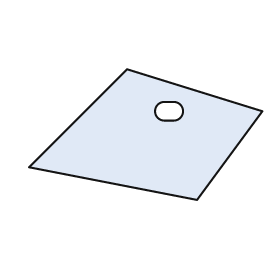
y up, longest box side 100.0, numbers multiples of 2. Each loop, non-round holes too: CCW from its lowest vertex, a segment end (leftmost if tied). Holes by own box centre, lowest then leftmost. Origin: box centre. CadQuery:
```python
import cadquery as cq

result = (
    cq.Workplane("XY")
    .moveTo(22.0, -28.0)
    .lineTo(50.0, 10.0)
    .lineTo(-8.0, 28.0)
    .lineTo(-50.0, -14.0)
    .close()
    .moveTo(8.0, 6.0)
    .lineTo(12.0, 6.0)
    .threePointArc((16.0, 10.0), (12.0, 14.0))
    .lineTo(8.0, 14.0)
    .threePointArc((4.0, 10.0), (8.0, 6.0))
    .close()
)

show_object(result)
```